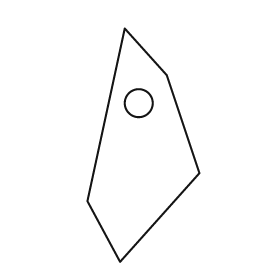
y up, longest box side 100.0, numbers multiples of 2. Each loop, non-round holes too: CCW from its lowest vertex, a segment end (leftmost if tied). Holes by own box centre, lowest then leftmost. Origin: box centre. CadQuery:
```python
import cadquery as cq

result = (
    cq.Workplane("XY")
    .moveTo(-10.0, -50.0)
    .lineTo(24.0, -12.0)
    .lineTo(10.0, 30.0)
    .lineTo(-8.0, 50.0)
    .lineTo(-24.0, -24.0)
    .close()
    .moveTo(-2.0, 18.0)
    .circle(6.0)
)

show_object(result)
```